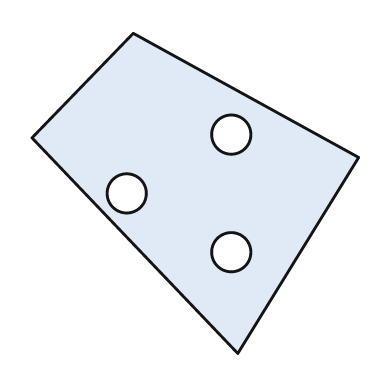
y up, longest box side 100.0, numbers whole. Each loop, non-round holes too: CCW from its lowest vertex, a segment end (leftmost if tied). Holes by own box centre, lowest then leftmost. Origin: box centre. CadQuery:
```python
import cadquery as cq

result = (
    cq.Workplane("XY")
    .moveTo(13.0, -49.0)
    .lineTo(50.0, 11.0)
    .lineTo(-19.0, 49.0)
    .lineTo(-50.0, 17.0)
    .close()
    .moveTo(11.0, -18.0)
    .circle(6.0)
    .moveTo(-21.0, 0.0)
    .circle(6.0)
    .moveTo(11.0, 18.0)
    .circle(6.0)
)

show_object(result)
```